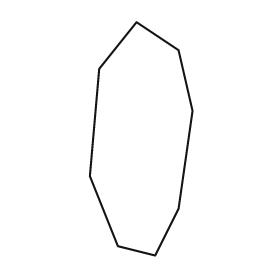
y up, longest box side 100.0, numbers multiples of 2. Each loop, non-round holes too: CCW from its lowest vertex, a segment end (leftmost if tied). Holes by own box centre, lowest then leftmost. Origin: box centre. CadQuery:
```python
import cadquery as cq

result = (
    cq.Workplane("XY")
    .moveTo(6.0, -50.0)
    .lineTo(16.0, -30.0)
    .lineTo(22.0, 12.0)
    .lineTo(16.0, 38.0)
    .lineTo(-2.0, 50.0)
    .lineTo(-18.0, 30.0)
    .lineTo(-22.0, -16.0)
    .lineTo(-10.0, -46.0)
    .close()
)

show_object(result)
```